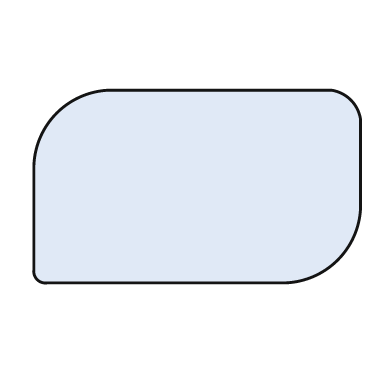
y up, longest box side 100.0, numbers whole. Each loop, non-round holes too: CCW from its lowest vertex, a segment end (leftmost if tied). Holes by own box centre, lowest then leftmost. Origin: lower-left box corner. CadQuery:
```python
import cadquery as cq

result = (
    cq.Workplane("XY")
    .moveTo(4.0, 0.0)
    .lineTo(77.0, 0.0)
    .threePointArc((93.0, 7.0), (100.0, 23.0))
    .lineTo(100.0, 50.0)
    .threePointArc((97.0, 56.0), (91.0, 59.0))
    .lineTo(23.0, 59.0)
    .threePointArc((7.0, 52.0), (0.0, 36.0))
    .lineTo(0.0, 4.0)
    .threePointArc((1.0, 1.0), (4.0, 0.0))
    .close()
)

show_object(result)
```